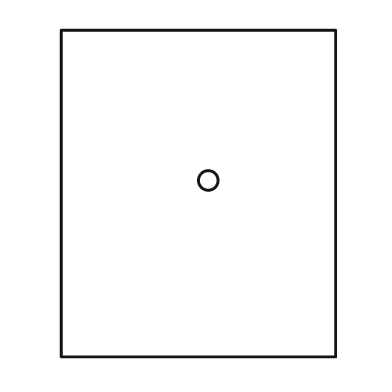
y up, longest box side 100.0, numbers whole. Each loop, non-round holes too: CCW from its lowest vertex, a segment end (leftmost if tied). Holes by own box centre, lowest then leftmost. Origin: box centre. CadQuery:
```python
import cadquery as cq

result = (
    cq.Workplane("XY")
    .moveTo(-42.0, -50.0)
    .lineTo(42.0, -50.0)
    .lineTo(42.0, 50.0)
    .lineTo(-42.0, 50.0)
    .close()
    .moveTo(3.0, 4.0)
    .circle(3.0)
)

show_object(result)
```